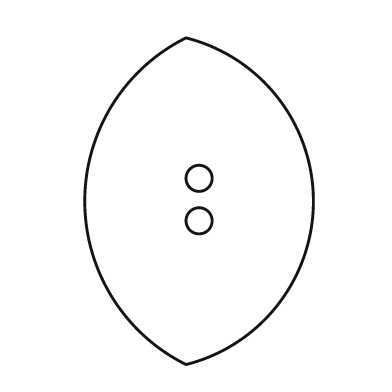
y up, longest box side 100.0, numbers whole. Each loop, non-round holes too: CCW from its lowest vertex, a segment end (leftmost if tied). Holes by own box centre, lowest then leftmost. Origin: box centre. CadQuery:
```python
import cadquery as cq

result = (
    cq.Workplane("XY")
    .moveTo(-4.0, -50.0)
    .threePointArc((35.0, 0.0), (-4.0, 50.0))
    .threePointArc((-35.0, 0.0), (-4.0, -50.0))
    .close()
    .moveTo(0.0, -6.0)
    .circle(4.0)
    .moveTo(0.0, 7.0)
    .circle(4.0)
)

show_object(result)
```